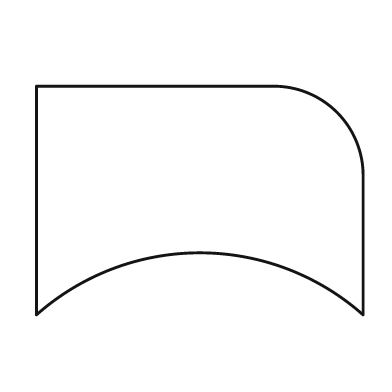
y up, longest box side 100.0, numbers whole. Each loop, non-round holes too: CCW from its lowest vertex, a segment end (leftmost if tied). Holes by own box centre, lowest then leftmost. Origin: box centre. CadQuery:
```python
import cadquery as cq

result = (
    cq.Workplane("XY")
    .moveTo(-50.0, -35.0)
    .threePointArc((0.0, -16.0), (50.0, -35.0))
    .lineTo(50.0, 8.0)
    .threePointArc((42.0, 27.0), (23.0, 35.0))
    .lineTo(-50.0, 35.0)
    .close()
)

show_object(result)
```